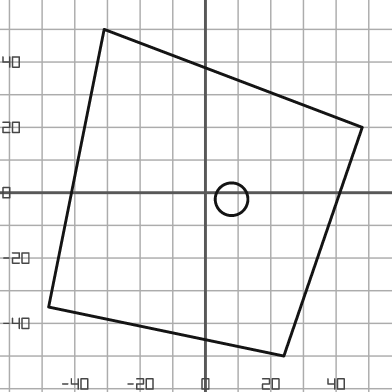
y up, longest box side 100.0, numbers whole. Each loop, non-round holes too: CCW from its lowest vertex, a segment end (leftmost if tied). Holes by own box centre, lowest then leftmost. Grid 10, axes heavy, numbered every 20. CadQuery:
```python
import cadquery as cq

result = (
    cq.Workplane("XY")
    .moveTo(24.0, -50.0)
    .lineTo(48.0, 20.0)
    .lineTo(-31.0, 50.0)
    .lineTo(-48.0, -35.0)
    .close()
    .moveTo(8.0, -2.0)
    .circle(5.0)
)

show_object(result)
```